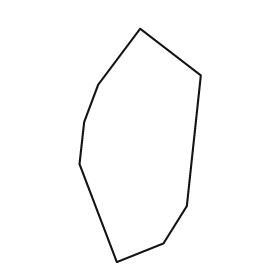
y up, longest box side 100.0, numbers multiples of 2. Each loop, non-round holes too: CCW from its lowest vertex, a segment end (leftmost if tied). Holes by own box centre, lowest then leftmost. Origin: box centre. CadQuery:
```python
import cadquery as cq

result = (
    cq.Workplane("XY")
    .moveTo(-10.0, -50.0)
    .lineTo(10.0, -42.0)
    .lineTo(20.0, -26.0)
    .lineTo(26.0, 30.0)
    .lineTo(0.0, 50.0)
    .lineTo(-18.0, 26.0)
    .lineTo(-24.0, 10.0)
    .lineTo(-26.0, -8.0)
    .close()
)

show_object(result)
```